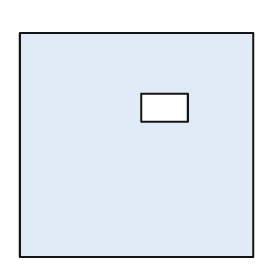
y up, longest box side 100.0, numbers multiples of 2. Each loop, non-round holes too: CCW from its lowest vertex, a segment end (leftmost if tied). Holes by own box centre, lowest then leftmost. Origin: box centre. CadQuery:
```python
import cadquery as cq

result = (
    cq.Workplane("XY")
    .moveTo(-50.0, -48.0)
    .lineTo(50.0, -48.0)
    .lineTo(50.0, 48.0)
    .lineTo(-50.0, 48.0)
    .close()
    .moveTo(2.0, 10.0)
    .lineTo(22.0, 10.0)
    .lineTo(22.0, 22.0)
    .lineTo(2.0, 22.0)
    .close()
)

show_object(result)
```